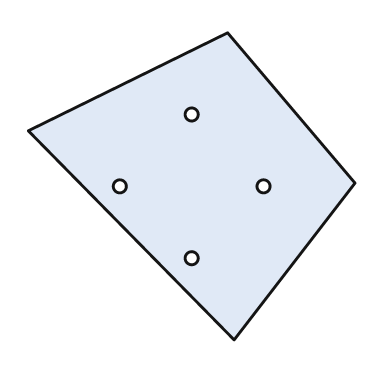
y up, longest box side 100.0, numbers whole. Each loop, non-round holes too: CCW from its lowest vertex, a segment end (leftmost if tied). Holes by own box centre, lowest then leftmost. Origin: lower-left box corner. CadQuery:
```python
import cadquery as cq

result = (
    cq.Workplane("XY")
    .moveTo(63.0, 0.0)
    .lineTo(100.0, 48.0)
    .lineTo(61.0, 94.0)
    .lineTo(0.0, 64.0)
    .close()
    .moveTo(50.0, 25.0)
    .circle(2.0)
    .moveTo(28.0, 47.0)
    .circle(2.0)
    .moveTo(72.0, 47.0)
    .circle(2.0)
    .moveTo(50.0, 69.0)
    .circle(2.0)
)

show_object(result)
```